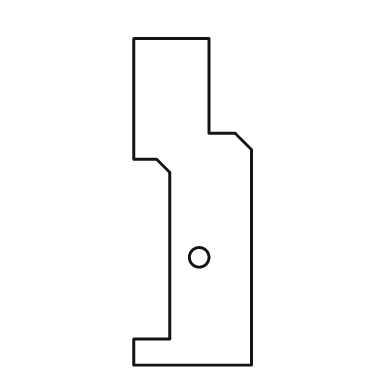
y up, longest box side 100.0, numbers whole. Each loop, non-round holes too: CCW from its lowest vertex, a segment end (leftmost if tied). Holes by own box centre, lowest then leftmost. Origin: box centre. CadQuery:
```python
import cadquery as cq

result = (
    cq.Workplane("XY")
    .moveTo(-18.0, -50.0)
    .lineTo(18.0, -50.0)
    .lineTo(18.0, 16.0)
    .lineTo(13.0, 21.0)
    .lineTo(5.0, 21.0)
    .lineTo(5.0, 50.0)
    .lineTo(-18.0, 50.0)
    .lineTo(-18.0, 13.0)
    .lineTo(-11.0, 13.0)
    .lineTo(-7.0, 9.0)
    .lineTo(-7.0, -42.0)
    .lineTo(-18.0, -42.0)
    .close()
    .moveTo(2.0, -17.0)
    .circle(3.0)
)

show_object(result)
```